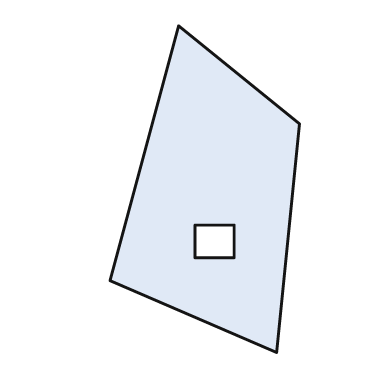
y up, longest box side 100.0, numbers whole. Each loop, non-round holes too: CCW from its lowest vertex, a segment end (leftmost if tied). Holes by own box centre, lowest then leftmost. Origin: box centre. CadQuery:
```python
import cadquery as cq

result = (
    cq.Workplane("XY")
    .moveTo(22.0, -50.0)
    .lineTo(29.0, 20.0)
    .lineTo(-8.0, 50.0)
    .lineTo(-29.0, -28.0)
    .close()
    .moveTo(-3.0, -21.0)
    .lineTo(9.0, -21.0)
    .lineTo(9.0, -11.0)
    .lineTo(-3.0, -11.0)
    .close()
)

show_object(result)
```